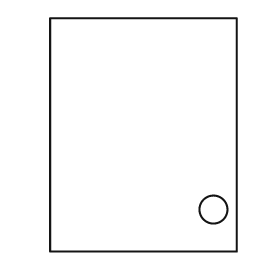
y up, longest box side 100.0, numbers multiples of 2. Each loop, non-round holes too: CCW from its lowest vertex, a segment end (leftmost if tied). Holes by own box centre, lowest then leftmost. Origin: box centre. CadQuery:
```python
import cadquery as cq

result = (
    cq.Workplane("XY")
    .moveTo(-40.0, -50.0)
    .lineTo(40.0, -50.0)
    .lineTo(40.0, 50.0)
    .lineTo(-40.0, 50.0)
    .close()
    .moveTo(30.0, -32.0)
    .circle(6.0)
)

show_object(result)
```